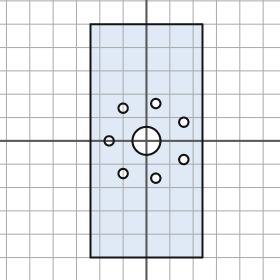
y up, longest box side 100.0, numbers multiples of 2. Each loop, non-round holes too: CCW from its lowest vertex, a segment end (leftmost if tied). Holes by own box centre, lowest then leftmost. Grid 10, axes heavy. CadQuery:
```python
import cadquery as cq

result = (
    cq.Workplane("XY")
    .moveTo(-24.0, -50.0)
    .lineTo(24.0, -50.0)
    .lineTo(24.0, 50.0)
    .lineTo(-24.0, 50.0)
    .close()
    .moveTo(4.0, -16.0)
    .circle(2.0)
    .moveTo(-10.0, -14.0)
    .circle(2.0)
    .moveTo(16.0, -8.0)
    .circle(2.0)
    .moveTo(-16.0, 0.0)
    .circle(2.0)
    .moveTo(0.0, 0.0)
    .circle(6.0)
    .moveTo(16.0, 8.0)
    .circle(2.0)
    .moveTo(-10.0, 14.0)
    .circle(2.0)
    .moveTo(4.0, 16.0)
    .circle(2.0)
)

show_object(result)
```